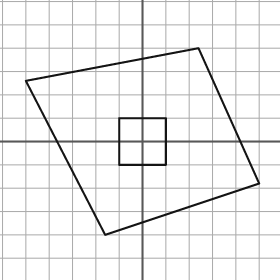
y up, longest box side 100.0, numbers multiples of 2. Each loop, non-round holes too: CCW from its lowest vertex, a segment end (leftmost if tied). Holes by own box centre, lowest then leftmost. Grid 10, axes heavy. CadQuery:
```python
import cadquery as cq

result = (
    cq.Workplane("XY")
    .moveTo(-16.0, -40.0)
    .lineTo(50.0, -18.0)
    .lineTo(24.0, 40.0)
    .lineTo(-50.0, 26.0)
    .close()
    .moveTo(-10.0, -10.0)
    .lineTo(10.0, -10.0)
    .lineTo(10.0, 10.0)
    .lineTo(-10.0, 10.0)
    .close()
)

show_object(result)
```